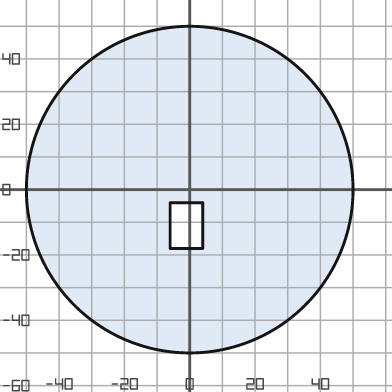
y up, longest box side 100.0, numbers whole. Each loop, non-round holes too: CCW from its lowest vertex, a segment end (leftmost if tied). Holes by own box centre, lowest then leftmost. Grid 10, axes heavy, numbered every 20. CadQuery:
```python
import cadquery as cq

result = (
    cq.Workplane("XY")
    .moveTo(0.0, 0.0)
    .circle(50.0)
    .moveTo(-6.0, -18.0)
    .lineTo(4.0, -18.0)
    .lineTo(4.0, -4.0)
    .lineTo(-6.0, -4.0)
    .close()
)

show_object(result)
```